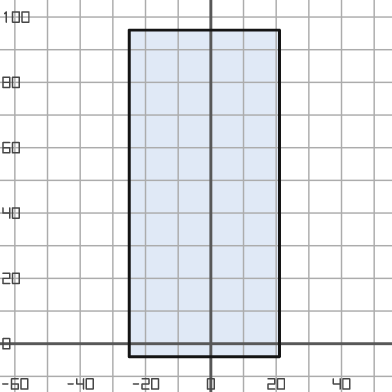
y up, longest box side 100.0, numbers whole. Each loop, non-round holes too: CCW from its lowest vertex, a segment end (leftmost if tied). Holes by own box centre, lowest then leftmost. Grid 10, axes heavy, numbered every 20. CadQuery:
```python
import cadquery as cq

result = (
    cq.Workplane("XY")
    .moveTo(-25.0, -4.0)
    .lineTo(21.0, -4.0)
    .lineTo(21.0, 96.0)
    .lineTo(-25.0, 96.0)
    .close()
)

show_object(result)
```